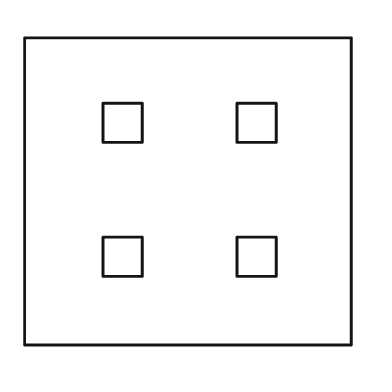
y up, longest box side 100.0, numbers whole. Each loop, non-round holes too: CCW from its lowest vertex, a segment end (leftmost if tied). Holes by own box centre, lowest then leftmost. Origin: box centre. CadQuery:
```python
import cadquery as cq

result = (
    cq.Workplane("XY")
    .moveTo(-50.0, -47.0)
    .lineTo(50.0, -47.0)
    .lineTo(50.0, 47.0)
    .lineTo(-50.0, 47.0)
    .close()
    .moveTo(-26.0, -26.0)
    .lineTo(-14.0, -26.0)
    .lineTo(-14.0, -14.0)
    .lineTo(-26.0, -14.0)
    .close()
    .moveTo(15.0, -26.0)
    .lineTo(27.0, -26.0)
    .lineTo(27.0, -14.0)
    .lineTo(15.0, -14.0)
    .close()
    .moveTo(-26.0, 15.0)
    .lineTo(-14.0, 15.0)
    .lineTo(-14.0, 27.0)
    .lineTo(-26.0, 27.0)
    .close()
    .moveTo(15.0, 15.0)
    .lineTo(27.0, 15.0)
    .lineTo(27.0, 27.0)
    .lineTo(15.0, 27.0)
    .close()
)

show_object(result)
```